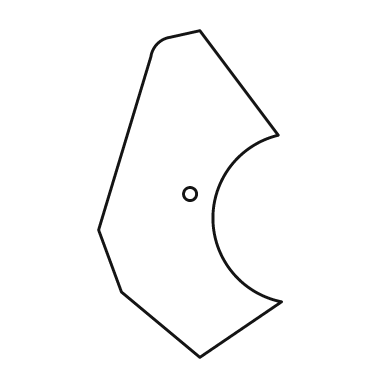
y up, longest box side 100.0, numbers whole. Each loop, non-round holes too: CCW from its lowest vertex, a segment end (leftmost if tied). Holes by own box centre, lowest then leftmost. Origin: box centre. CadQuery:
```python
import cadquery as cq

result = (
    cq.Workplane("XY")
    .moveTo(3.0, -50.0)
    .lineTo(28.0, -33.0)
    .threePointArc((7.0, -8.0), (27.0, 18.0))
    .lineTo(3.0, 50.0)
    .lineTo(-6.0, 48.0)
    .threePointArc((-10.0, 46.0), (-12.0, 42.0))
    .lineTo(-28.0, -11.0)
    .lineTo(-21.0, -30.0)
    .close()
    .moveTo(0.0, 0.0)
    .circle(2.0)
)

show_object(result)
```